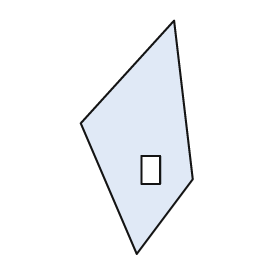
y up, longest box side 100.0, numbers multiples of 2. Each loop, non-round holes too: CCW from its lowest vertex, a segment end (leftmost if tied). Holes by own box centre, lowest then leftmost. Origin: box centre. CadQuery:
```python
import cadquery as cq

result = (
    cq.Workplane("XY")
    .moveTo(0.0, -50.0)
    .lineTo(24.0, -18.0)
    .lineTo(16.0, 50.0)
    .lineTo(-24.0, 6.0)
    .close()
    .moveTo(2.0, -20.0)
    .lineTo(10.0, -20.0)
    .lineTo(10.0, -8.0)
    .lineTo(2.0, -8.0)
    .close()
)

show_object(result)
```